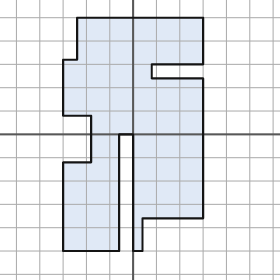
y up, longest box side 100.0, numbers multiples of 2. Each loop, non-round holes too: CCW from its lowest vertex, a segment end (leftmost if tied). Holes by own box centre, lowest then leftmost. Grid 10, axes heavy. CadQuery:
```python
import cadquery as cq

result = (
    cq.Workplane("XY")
    .moveTo(-30.0, -50.0)
    .lineTo(-6.0, -50.0)
    .lineTo(-6.0, 0.0)
    .lineTo(0.0, 0.0)
    .lineTo(0.0, -50.0)
    .lineTo(4.0, -50.0)
    .lineTo(4.0, -36.0)
    .lineTo(30.0, -36.0)
    .lineTo(30.0, 24.0)
    .lineTo(8.0, 24.0)
    .lineTo(8.0, 30.0)
    .lineTo(30.0, 30.0)
    .lineTo(30.0, 50.0)
    .lineTo(-24.0, 50.0)
    .lineTo(-24.0, 32.0)
    .lineTo(-30.0, 32.0)
    .lineTo(-30.0, 8.0)
    .lineTo(-18.0, 8.0)
    .lineTo(-18.0, -12.0)
    .lineTo(-30.0, -12.0)
    .close()
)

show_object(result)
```